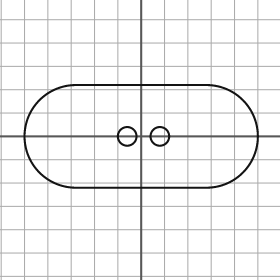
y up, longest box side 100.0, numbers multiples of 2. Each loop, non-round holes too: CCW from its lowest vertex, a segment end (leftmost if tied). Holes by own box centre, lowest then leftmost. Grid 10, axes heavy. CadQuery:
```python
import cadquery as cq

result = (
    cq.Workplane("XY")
    .moveTo(-28.0, -22.0)
    .lineTo(28.0, -22.0)
    .threePointArc((50.0, 0.0), (28.0, 22.0))
    .lineTo(-28.0, 22.0)
    .threePointArc((-50.0, 0.0), (-28.0, -22.0))
    .close()
    .moveTo(-6.0, 0.0)
    .circle(4.0)
    .moveTo(8.0, 0.0)
    .circle(4.0)
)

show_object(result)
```